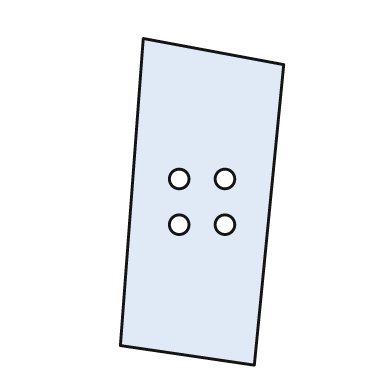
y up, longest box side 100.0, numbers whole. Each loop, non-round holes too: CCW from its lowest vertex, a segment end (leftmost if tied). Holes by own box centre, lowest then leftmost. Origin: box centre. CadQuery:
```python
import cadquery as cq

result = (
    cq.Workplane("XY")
    .moveTo(16.0, -50.0)
    .lineTo(25.0, 42.0)
    .lineTo(-18.0, 50.0)
    .lineTo(-25.0, -44.0)
    .close()
    .moveTo(-7.0, -7.0)
    .circle(3.0)
    .moveTo(7.0, -7.0)
    .circle(3.0)
    .moveTo(-7.0, 7.0)
    .circle(3.0)
    .moveTo(7.0, 7.0)
    .circle(3.0)
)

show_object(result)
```